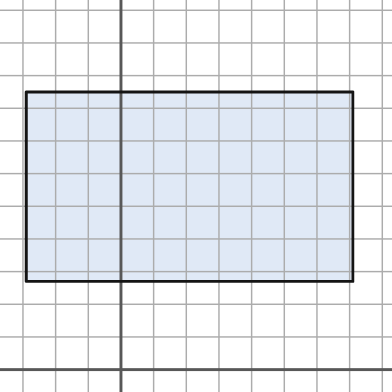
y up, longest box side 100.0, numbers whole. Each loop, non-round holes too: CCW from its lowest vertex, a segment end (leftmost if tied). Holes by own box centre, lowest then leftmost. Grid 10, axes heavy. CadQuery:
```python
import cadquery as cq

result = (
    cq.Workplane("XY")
    .moveTo(-29.0, 27.0)
    .lineTo(71.0, 27.0)
    .lineTo(71.0, 85.0)
    .lineTo(-29.0, 85.0)
    .close()
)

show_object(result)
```